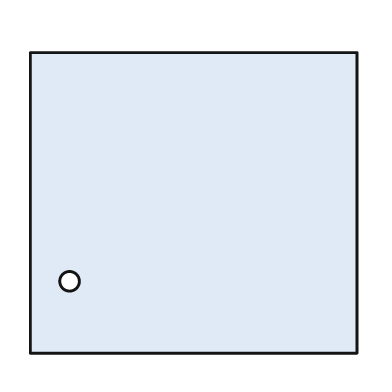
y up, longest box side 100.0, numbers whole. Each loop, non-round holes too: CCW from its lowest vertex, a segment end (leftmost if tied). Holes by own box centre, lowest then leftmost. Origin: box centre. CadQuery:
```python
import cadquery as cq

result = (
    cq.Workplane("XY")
    .moveTo(-50.0, -46.0)
    .lineTo(50.0, -46.0)
    .lineTo(50.0, 46.0)
    .lineTo(-50.0, 46.0)
    .close()
    .moveTo(-38.0, -24.0)
    .circle(3.0)
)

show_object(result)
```